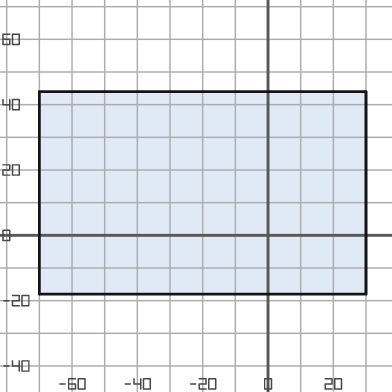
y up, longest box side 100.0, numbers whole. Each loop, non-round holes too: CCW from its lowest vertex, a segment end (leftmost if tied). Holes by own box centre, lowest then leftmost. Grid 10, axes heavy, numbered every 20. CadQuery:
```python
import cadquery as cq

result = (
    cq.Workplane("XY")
    .moveTo(-70.0, -18.0)
    .lineTo(30.0, -18.0)
    .lineTo(30.0, 44.0)
    .lineTo(-70.0, 44.0)
    .close()
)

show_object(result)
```